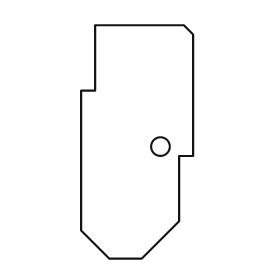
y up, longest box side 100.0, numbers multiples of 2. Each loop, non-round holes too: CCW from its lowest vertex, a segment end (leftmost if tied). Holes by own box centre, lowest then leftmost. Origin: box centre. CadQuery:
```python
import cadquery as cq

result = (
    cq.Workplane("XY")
    .moveTo(-12.0, -50.0)
    .lineTo(2.0, -50.0)
    .lineTo(18.0, -34.0)
    .lineTo(18.0, -6.0)
    .lineTo(24.0, -6.0)
    .lineTo(24.0, 46.0)
    .lineTo(20.0, 50.0)
    .lineTo(-18.0, 50.0)
    .lineTo(-18.0, 22.0)
    .lineTo(-24.0, 22.0)
    .lineTo(-24.0, -38.0)
    .close()
    .moveTo(10.0, -2.0)
    .circle(4.0)
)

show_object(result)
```